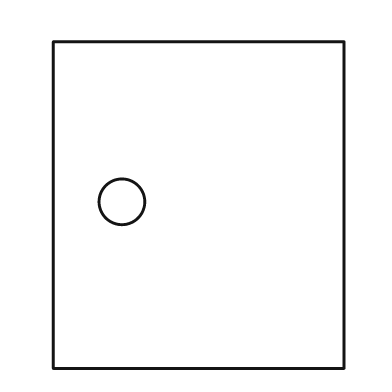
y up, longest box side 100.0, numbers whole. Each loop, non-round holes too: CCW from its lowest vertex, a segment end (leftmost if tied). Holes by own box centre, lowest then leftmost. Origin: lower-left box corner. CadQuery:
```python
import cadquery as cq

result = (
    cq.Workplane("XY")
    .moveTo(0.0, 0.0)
    .lineTo(89.0, 0.0)
    .lineTo(89.0, 100.0)
    .lineTo(0.0, 100.0)
    .close()
    .moveTo(21.0, 51.0)
    .circle(7.0)
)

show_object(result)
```